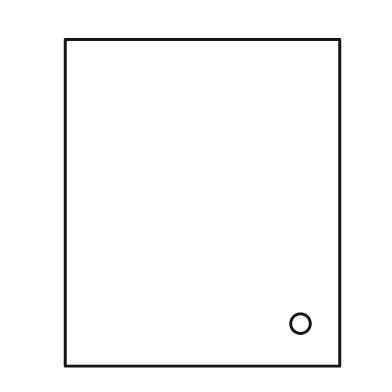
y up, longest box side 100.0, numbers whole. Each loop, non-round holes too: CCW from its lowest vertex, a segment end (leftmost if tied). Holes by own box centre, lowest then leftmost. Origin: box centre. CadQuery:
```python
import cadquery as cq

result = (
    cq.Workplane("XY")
    .moveTo(-42.0, -50.0)
    .lineTo(42.0, -50.0)
    .lineTo(42.0, 50.0)
    .lineTo(-42.0, 50.0)
    .close()
    .moveTo(30.0, -37.0)
    .circle(3.0)
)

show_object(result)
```